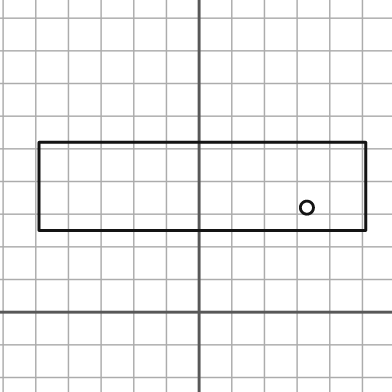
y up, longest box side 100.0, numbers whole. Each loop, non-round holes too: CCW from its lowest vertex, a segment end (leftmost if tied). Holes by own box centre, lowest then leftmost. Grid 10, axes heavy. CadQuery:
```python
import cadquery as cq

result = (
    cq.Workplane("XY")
    .moveTo(-49.0, 25.0)
    .lineTo(51.0, 25.0)
    .lineTo(51.0, 52.0)
    .lineTo(-49.0, 52.0)
    .close()
    .moveTo(33.0, 32.0)
    .circle(2.0)
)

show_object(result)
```